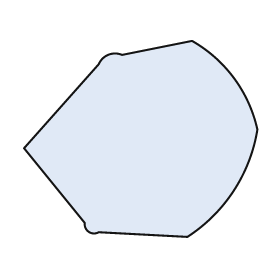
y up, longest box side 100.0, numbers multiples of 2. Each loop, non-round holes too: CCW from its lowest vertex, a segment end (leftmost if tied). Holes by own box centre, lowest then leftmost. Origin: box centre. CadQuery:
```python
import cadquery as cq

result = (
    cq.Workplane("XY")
    .moveTo(20.0, -42.0)
    .threePointArc((40.0, -22.0), (50.0, 4.0))
    .threePointArc((40.0, 26.0), (22.0, 42.0))
    .lineTo(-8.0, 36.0)
    .threePointArc((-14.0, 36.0), (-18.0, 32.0))
    .lineTo(-50.0, -4.0)
    .lineTo(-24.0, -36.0)
    .threePointArc((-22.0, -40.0), (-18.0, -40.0))
    .close()
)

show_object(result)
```